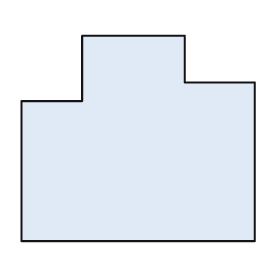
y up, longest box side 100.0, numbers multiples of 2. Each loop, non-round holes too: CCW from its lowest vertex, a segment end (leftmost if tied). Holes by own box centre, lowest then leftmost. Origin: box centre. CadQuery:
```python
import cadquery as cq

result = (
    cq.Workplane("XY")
    .moveTo(-50.0, -44.0)
    .lineTo(50.0, -44.0)
    .lineTo(50.0, 24.0)
    .lineTo(20.0, 24.0)
    .lineTo(20.0, 44.0)
    .lineTo(-24.0, 44.0)
    .lineTo(-24.0, 16.0)
    .lineTo(-50.0, 16.0)
    .close()
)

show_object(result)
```